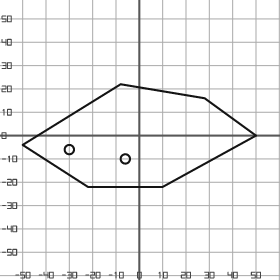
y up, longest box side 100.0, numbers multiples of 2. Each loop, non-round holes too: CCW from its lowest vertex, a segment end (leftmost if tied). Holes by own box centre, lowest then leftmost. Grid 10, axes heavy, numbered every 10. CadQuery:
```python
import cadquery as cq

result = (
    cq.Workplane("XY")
    .moveTo(-22.0, -22.0)
    .lineTo(10.0, -22.0)
    .lineTo(50.0, 0.0)
    .lineTo(28.0, 16.0)
    .lineTo(-8.0, 22.0)
    .lineTo(-50.0, -4.0)
    .close()
    .moveTo(-6.0, -10.0)
    .circle(2.0)
    .moveTo(-30.0, -6.0)
    .circle(2.0)
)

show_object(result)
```